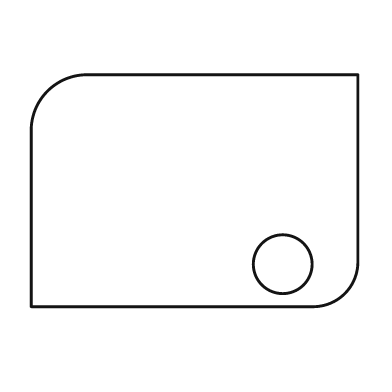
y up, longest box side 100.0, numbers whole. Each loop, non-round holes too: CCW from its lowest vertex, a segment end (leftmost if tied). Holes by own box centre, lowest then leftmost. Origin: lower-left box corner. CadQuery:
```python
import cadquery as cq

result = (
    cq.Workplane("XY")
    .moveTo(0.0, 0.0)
    .lineTo(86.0, 0.0)
    .threePointArc((96.0, 4.0), (100.0, 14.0))
    .lineTo(100.0, 71.0)
    .lineTo(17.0, 71.0)
    .threePointArc((5.0, 66.0), (0.0, 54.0))
    .close()
    .moveTo(77.0, 13.0)
    .circle(9.0)
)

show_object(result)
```